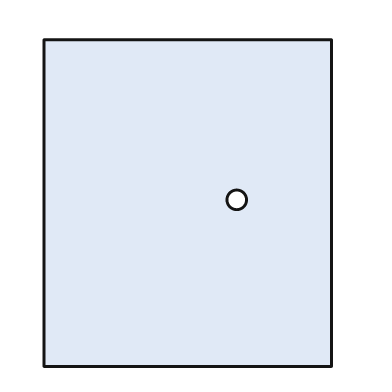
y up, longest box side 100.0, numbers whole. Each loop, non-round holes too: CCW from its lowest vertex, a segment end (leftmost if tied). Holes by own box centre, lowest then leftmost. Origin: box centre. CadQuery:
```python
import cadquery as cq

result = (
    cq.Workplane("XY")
    .moveTo(-44.0, -50.0)
    .lineTo(44.0, -50.0)
    .lineTo(44.0, 50.0)
    .lineTo(-44.0, 50.0)
    .close()
    .moveTo(15.0, 1.0)
    .circle(3.0)
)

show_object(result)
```